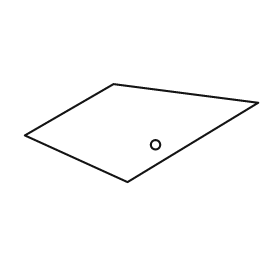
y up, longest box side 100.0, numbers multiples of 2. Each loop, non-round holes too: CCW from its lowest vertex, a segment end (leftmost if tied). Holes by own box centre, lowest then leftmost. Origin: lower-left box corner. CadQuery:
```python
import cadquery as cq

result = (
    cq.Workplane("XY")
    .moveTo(44.0, 0.0)
    .lineTo(100.0, 34.0)
    .lineTo(38.0, 42.0)
    .lineTo(0.0, 20.0)
    .close()
    .moveTo(56.0, 16.0)
    .circle(2.0)
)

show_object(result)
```